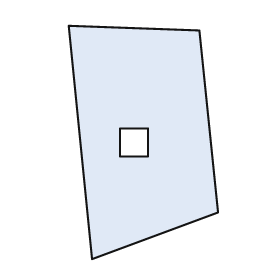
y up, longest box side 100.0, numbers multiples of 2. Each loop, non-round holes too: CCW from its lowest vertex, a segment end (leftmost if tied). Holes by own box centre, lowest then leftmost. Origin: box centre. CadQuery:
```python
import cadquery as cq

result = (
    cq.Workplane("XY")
    .moveTo(-22.0, -50.0)
    .lineTo(32.0, -30.0)
    .lineTo(24.0, 48.0)
    .lineTo(-32.0, 50.0)
    .close()
    .moveTo(-10.0, -6.0)
    .lineTo(2.0, -6.0)
    .lineTo(2.0, 6.0)
    .lineTo(-10.0, 6.0)
    .close()
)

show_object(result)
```